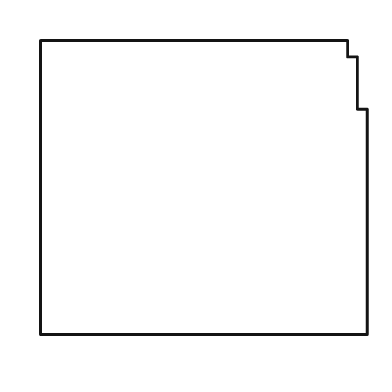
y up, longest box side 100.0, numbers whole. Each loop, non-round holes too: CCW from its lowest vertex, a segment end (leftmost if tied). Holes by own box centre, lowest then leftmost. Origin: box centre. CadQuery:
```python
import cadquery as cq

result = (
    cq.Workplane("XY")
    .moveTo(-50.0, -45.0)
    .lineTo(50.0, -45.0)
    .lineTo(50.0, 24.0)
    .lineTo(47.0, 24.0)
    .lineTo(47.0, 40.0)
    .lineTo(44.0, 40.0)
    .lineTo(44.0, 45.0)
    .lineTo(-50.0, 45.0)
    .close()
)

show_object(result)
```